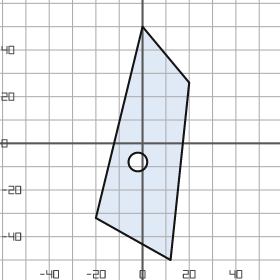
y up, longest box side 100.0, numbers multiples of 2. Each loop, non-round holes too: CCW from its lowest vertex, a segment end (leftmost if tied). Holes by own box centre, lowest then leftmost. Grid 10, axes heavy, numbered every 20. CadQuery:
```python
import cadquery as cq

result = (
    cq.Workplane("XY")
    .moveTo(12.0, -50.0)
    .lineTo(20.0, 26.0)
    .lineTo(0.0, 50.0)
    .lineTo(-20.0, -32.0)
    .close()
    .moveTo(-2.0, -8.0)
    .circle(4.0)
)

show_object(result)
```